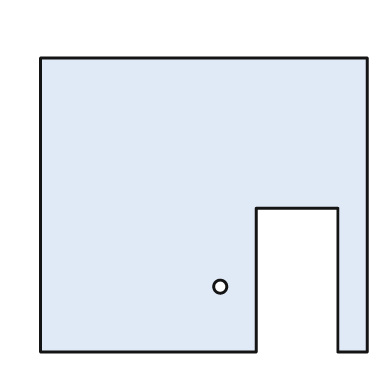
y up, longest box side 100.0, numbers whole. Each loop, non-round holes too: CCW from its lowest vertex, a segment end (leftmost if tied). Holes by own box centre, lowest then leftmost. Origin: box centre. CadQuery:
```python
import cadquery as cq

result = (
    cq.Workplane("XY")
    .moveTo(-50.0, -45.0)
    .lineTo(16.0, -45.0)
    .lineTo(16.0, -1.0)
    .lineTo(41.0, -1.0)
    .lineTo(41.0, -45.0)
    .lineTo(50.0, -45.0)
    .lineTo(50.0, 45.0)
    .lineTo(-50.0, 45.0)
    .close()
    .moveTo(5.0, -25.0)
    .circle(2.0)
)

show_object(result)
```